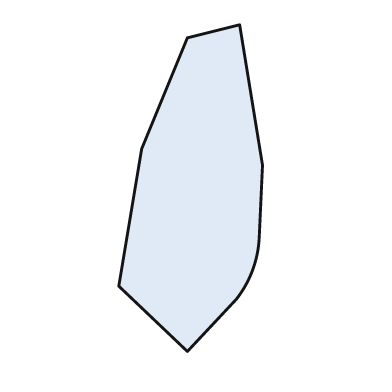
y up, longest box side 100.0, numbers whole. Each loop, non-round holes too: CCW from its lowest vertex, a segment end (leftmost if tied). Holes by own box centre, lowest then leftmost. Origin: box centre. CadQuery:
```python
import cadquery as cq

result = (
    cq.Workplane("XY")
    .moveTo(-1.0, -50.0)
    .lineTo(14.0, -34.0)
    .threePointArc((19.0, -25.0), (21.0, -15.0))
    .lineTo(22.0, 7.0)
    .lineTo(15.0, 50.0)
    .lineTo(-1.0, 46.0)
    .lineTo(-15.0, 12.0)
    .lineTo(-22.0, -30.0)
    .close()
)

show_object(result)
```